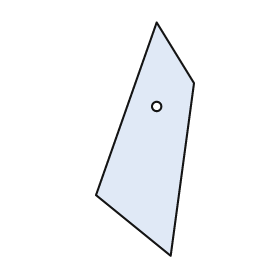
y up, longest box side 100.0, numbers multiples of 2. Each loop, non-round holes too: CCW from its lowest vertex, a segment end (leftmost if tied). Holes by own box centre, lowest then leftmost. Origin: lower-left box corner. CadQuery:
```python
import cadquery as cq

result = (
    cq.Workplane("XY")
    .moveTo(32.0, 0.0)
    .lineTo(42.0, 74.0)
    .lineTo(26.0, 100.0)
    .lineTo(0.0, 26.0)
    .close()
    .moveTo(26.0, 64.0)
    .circle(2.0)
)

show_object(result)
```